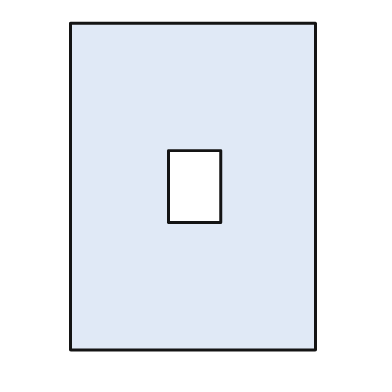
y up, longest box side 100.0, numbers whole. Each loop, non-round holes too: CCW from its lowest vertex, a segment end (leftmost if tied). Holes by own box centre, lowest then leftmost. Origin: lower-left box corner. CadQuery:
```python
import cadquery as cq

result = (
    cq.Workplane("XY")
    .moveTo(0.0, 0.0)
    .lineTo(75.0, 0.0)
    .lineTo(75.0, 100.0)
    .lineTo(0.0, 100.0)
    .close()
    .moveTo(30.0, 39.0)
    .lineTo(46.0, 39.0)
    .lineTo(46.0, 61.0)
    .lineTo(30.0, 61.0)
    .close()
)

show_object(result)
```